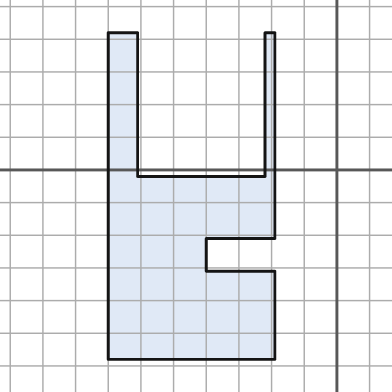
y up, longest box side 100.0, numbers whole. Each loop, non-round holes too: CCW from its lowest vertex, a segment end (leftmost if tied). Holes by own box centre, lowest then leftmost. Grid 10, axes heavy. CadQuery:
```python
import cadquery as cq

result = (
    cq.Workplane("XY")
    .moveTo(-70.0, -58.0)
    .lineTo(-19.0, -58.0)
    .lineTo(-19.0, -31.0)
    .lineTo(-40.0, -31.0)
    .lineTo(-40.0, -21.0)
    .lineTo(-19.0, -21.0)
    .lineTo(-19.0, 42.0)
    .lineTo(-22.0, 42.0)
    .lineTo(-22.0, -2.0)
    .lineTo(-61.0, -2.0)
    .lineTo(-61.0, 42.0)
    .lineTo(-70.0, 42.0)
    .close()
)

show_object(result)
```